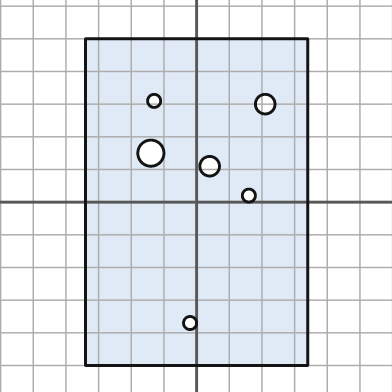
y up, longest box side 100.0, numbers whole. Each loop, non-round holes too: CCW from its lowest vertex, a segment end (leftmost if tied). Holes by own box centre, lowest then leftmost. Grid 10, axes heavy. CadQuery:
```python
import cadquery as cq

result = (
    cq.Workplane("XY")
    .moveTo(-34.0, -50.0)
    .lineTo(34.0, -50.0)
    .lineTo(34.0, 50.0)
    .lineTo(-34.0, 50.0)
    .close()
    .moveTo(-2.0, -37.0)
    .circle(2.0)
    .moveTo(16.0, 2.0)
    .circle(2.0)
    .moveTo(4.0, 11.0)
    .circle(3.0)
    .moveTo(-14.0, 15.0)
    .circle(4.0)
    .moveTo(21.0, 30.0)
    .circle(3.0)
    .moveTo(-13.0, 31.0)
    .circle(2.0)
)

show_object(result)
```